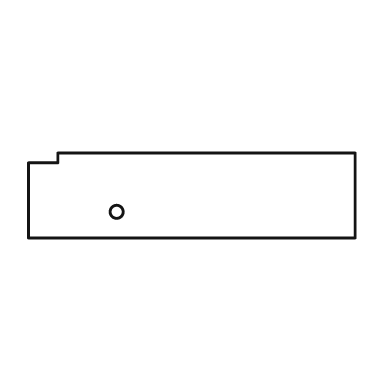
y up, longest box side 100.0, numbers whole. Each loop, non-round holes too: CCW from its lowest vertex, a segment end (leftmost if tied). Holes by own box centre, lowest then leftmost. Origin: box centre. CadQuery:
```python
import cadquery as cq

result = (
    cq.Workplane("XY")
    .moveTo(-50.0, -13.0)
    .lineTo(50.0, -13.0)
    .lineTo(50.0, 13.0)
    .lineTo(-41.0, 13.0)
    .lineTo(-41.0, 10.0)
    .lineTo(-50.0, 10.0)
    .close()
    .moveTo(-23.0, -5.0)
    .circle(2.0)
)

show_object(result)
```